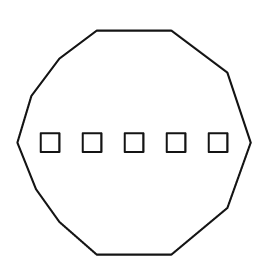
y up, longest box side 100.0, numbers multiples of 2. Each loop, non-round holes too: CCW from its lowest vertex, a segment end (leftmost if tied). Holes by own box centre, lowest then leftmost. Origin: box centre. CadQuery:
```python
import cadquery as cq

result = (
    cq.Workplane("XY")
    .moveTo(-16.0, -48.0)
    .lineTo(16.0, -48.0)
    .lineTo(40.0, -28.0)
    .lineTo(50.0, 0.0)
    .lineTo(40.0, 30.0)
    .lineTo(16.0, 48.0)
    .lineTo(-16.0, 48.0)
    .lineTo(-32.0, 36.0)
    .lineTo(-44.0, 20.0)
    .lineTo(-50.0, 0.0)
    .lineTo(-42.0, -20.0)
    .lineTo(-32.0, -34.0)
    .close()
    .moveTo(-40.0, -4.0)
    .lineTo(-32.0, -4.0)
    .lineTo(-32.0, 4.0)
    .lineTo(-40.0, 4.0)
    .close()
    .moveTo(-22.0, -4.0)
    .lineTo(-14.0, -4.0)
    .lineTo(-14.0, 4.0)
    .lineTo(-22.0, 4.0)
    .close()
    .moveTo(-4.0, -4.0)
    .lineTo(4.0, -4.0)
    .lineTo(4.0, 4.0)
    .lineTo(-4.0, 4.0)
    .close()
    .moveTo(14.0, -4.0)
    .lineTo(22.0, -4.0)
    .lineTo(22.0, 4.0)
    .lineTo(14.0, 4.0)
    .close()
    .moveTo(32.0, -4.0)
    .lineTo(40.0, -4.0)
    .lineTo(40.0, 4.0)
    .lineTo(32.0, 4.0)
    .close()
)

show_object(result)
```